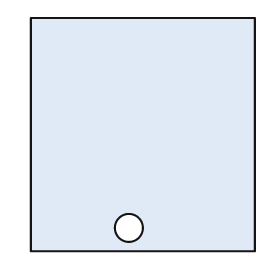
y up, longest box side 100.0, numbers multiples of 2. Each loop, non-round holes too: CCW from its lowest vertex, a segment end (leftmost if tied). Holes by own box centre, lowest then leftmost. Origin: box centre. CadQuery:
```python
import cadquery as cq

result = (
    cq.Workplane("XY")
    .moveTo(-48.0, -50.0)
    .lineTo(48.0, -50.0)
    .lineTo(48.0, 50.0)
    .lineTo(-48.0, 50.0)
    .close()
    .moveTo(-6.0, -40.0)
    .circle(6.0)
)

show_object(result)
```